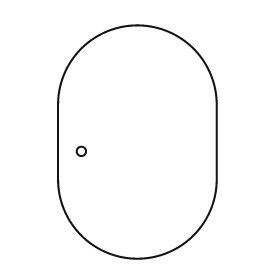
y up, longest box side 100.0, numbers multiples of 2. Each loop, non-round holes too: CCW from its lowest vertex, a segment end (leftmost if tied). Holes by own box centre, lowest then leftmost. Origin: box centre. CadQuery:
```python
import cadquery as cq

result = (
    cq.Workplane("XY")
    .moveTo(-34.0, -16.0)
    .threePointArc((0.0, -50.0), (34.0, -16.0))
    .lineTo(34.0, 16.0)
    .threePointArc((0.0, 50.0), (-34.0, 16.0))
    .close()
    .moveTo(-24.0, -4.0)
    .circle(2.0)
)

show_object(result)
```